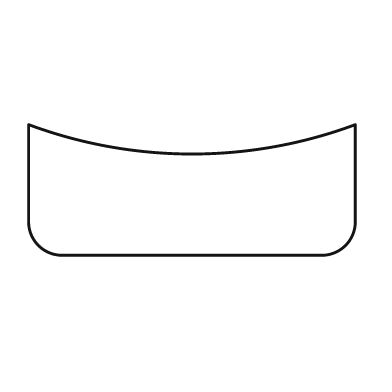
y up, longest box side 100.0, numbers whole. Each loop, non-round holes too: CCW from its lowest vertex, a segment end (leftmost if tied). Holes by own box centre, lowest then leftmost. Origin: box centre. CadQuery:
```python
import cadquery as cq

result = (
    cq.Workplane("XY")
    .moveTo(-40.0, -20.0)
    .lineTo(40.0, -20.0)
    .threePointArc((47.0, -17.0), (50.0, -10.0))
    .lineTo(50.0, 20.0)
    .threePointArc((0.0, 11.0), (-50.0, 20.0))
    .lineTo(-50.0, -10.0)
    .threePointArc((-47.0, -17.0), (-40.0, -20.0))
    .close()
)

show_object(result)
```